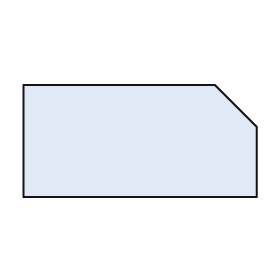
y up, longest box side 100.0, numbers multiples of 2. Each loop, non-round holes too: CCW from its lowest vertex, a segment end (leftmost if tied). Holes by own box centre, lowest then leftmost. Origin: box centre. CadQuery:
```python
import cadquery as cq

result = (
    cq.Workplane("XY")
    .moveTo(-50.0, -24.0)
    .lineTo(50.0, -24.0)
    .lineTo(50.0, 6.0)
    .lineTo(32.0, 24.0)
    .lineTo(-50.0, 24.0)
    .close()
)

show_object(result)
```